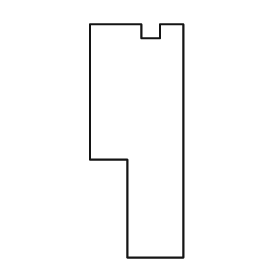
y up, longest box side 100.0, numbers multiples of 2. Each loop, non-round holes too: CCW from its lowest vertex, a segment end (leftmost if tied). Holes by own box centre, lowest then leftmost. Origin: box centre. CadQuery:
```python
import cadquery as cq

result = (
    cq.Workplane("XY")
    .moveTo(-4.0, -50.0)
    .lineTo(20.0, -50.0)
    .lineTo(20.0, 50.0)
    .lineTo(10.0, 50.0)
    .lineTo(10.0, 44.0)
    .lineTo(2.0, 44.0)
    .lineTo(2.0, 50.0)
    .lineTo(-20.0, 50.0)
    .lineTo(-20.0, -8.0)
    .lineTo(-4.0, -8.0)
    .close()
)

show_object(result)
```